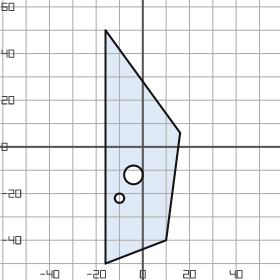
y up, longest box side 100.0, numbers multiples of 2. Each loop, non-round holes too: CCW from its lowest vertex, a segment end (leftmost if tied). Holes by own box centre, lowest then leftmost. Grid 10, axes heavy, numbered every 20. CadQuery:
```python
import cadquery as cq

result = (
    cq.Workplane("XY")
    .moveTo(-16.0, -50.0)
    .lineTo(10.0, -40.0)
    .lineTo(16.0, 6.0)
    .lineTo(-16.0, 50.0)
    .close()
    .moveTo(-10.0, -22.0)
    .circle(2.0)
    .moveTo(-4.0, -12.0)
    .circle(4.0)
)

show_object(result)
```